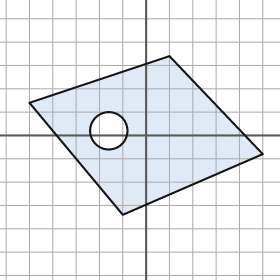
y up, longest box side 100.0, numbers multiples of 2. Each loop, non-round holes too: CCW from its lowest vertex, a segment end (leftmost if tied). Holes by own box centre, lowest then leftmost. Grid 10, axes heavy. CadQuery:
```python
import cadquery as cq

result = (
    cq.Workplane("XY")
    .moveTo(-10.0, -34.0)
    .lineTo(50.0, -8.0)
    .lineTo(10.0, 34.0)
    .lineTo(-50.0, 14.0)
    .close()
    .moveTo(-16.0, 2.0)
    .circle(8.0)
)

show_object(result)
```